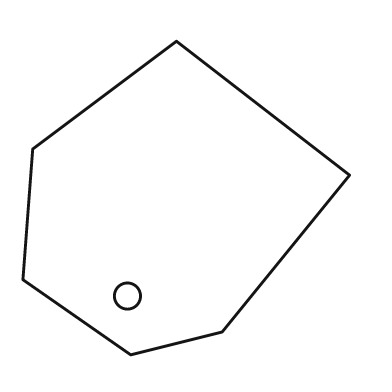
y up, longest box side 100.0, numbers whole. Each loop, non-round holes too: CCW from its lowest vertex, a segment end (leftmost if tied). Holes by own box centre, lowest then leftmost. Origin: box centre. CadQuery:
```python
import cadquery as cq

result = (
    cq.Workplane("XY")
    .moveTo(-17.0, -48.0)
    .lineTo(11.0, -41.0)
    .lineTo(50.0, 7.0)
    .lineTo(-3.0, 48.0)
    .lineTo(-47.0, 15.0)
    .lineTo(-50.0, -25.0)
    .close()
    .moveTo(-18.0, -30.0)
    .circle(4.0)
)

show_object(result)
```